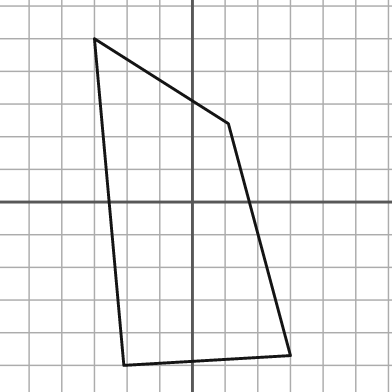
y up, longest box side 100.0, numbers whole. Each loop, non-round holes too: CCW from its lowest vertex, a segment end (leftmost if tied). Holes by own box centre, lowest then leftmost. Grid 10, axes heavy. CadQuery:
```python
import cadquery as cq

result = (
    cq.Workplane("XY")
    .moveTo(-21.0, -50.0)
    .lineTo(30.0, -47.0)
    .lineTo(11.0, 24.0)
    .lineTo(-30.0, 50.0)
    .close()
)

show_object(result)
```